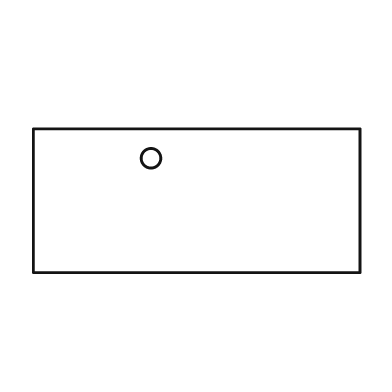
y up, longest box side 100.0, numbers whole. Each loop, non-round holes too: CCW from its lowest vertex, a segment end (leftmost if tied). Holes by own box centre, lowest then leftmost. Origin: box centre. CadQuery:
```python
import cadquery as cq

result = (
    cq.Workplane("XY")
    .moveTo(-50.0, -22.0)
    .lineTo(50.0, -22.0)
    .lineTo(50.0, 22.0)
    .lineTo(-50.0, 22.0)
    .close()
    .moveTo(-14.0, 13.0)
    .circle(3.0)
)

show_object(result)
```